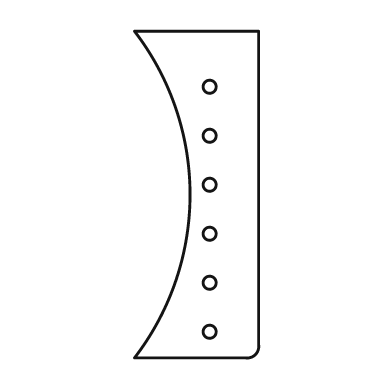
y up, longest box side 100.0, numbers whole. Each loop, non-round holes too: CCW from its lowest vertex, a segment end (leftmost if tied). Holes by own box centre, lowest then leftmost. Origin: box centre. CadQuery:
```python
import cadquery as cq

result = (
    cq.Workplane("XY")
    .moveTo(-19.0, -50.0)
    .lineTo(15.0, -50.0)
    .threePointArc((18.0, -49.0), (19.0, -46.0))
    .lineTo(19.0, 50.0)
    .lineTo(-19.0, 50.0)
    .threePointArc((-2.0, 0.0), (-19.0, -50.0))
    .close()
    .moveTo(4.0, -42.0)
    .circle(2.0)
    .moveTo(4.0, -27.0)
    .circle(2.0)
    .moveTo(4.0, -12.0)
    .circle(2.0)
    .moveTo(4.0, 3.0)
    .circle(2.0)
    .moveTo(4.0, 18.0)
    .circle(2.0)
    .moveTo(4.0, 33.0)
    .circle(2.0)
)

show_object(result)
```